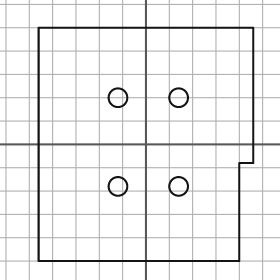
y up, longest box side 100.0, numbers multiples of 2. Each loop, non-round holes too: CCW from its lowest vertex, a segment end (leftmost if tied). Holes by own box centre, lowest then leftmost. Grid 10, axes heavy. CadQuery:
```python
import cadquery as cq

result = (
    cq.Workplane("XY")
    .moveTo(-46.0, -50.0)
    .lineTo(40.0, -50.0)
    .lineTo(40.0, -8.0)
    .lineTo(46.0, -8.0)
    .lineTo(46.0, 50.0)
    .lineTo(-46.0, 50.0)
    .close()
    .moveTo(-12.0, -18.0)
    .circle(4.0)
    .moveTo(14.0, -18.0)
    .circle(4.0)
    .moveTo(-12.0, 20.0)
    .circle(4.0)
    .moveTo(14.0, 20.0)
    .circle(4.0)
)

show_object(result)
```